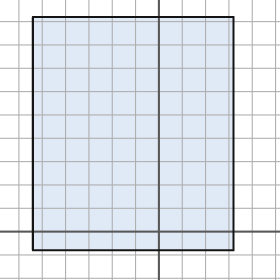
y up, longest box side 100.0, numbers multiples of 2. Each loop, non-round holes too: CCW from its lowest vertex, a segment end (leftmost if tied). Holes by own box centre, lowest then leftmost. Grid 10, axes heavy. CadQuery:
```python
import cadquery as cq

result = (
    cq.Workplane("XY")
    .moveTo(-54.0, -8.0)
    .lineTo(32.0, -8.0)
    .lineTo(32.0, 92.0)
    .lineTo(-54.0, 92.0)
    .close()
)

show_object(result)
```